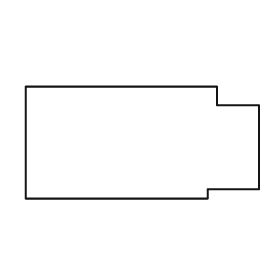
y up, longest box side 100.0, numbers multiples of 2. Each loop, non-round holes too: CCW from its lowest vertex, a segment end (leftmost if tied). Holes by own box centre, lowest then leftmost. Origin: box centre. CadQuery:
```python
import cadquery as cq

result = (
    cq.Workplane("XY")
    .moveTo(-50.0, -24.0)
    .lineTo(28.0, -24.0)
    .lineTo(28.0, -20.0)
    .lineTo(50.0, -20.0)
    .lineTo(50.0, 16.0)
    .lineTo(32.0, 16.0)
    .lineTo(32.0, 24.0)
    .lineTo(-50.0, 24.0)
    .close()
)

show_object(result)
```